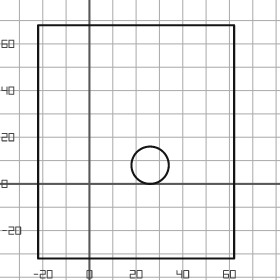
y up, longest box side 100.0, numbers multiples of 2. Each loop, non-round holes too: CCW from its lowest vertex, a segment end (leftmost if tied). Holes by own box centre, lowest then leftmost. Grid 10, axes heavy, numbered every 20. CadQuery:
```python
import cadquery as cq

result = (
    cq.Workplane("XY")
    .moveTo(-22.0, -32.0)
    .lineTo(62.0, -32.0)
    .lineTo(62.0, 68.0)
    .lineTo(-22.0, 68.0)
    .close()
    .moveTo(26.0, 8.0)
    .circle(8.0)
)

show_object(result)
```